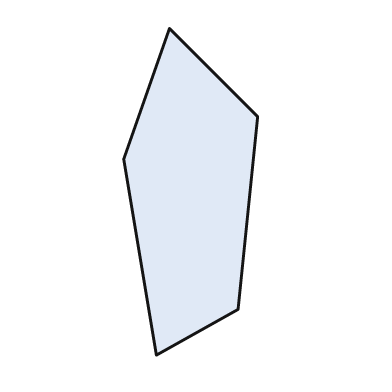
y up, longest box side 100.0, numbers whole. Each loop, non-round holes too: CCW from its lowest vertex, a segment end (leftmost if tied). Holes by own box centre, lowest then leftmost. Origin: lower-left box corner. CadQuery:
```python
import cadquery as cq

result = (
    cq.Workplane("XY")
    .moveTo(10.0, 0.0)
    .lineTo(35.0, 14.0)
    .lineTo(41.0, 73.0)
    .lineTo(14.0, 100.0)
    .lineTo(0.0, 60.0)
    .close()
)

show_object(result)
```